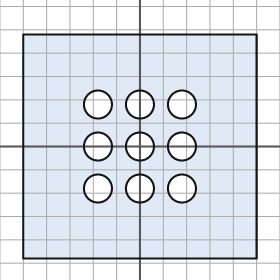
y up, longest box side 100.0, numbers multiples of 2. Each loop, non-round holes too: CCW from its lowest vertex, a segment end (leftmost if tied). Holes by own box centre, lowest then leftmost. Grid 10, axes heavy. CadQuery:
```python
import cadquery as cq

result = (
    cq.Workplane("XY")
    .moveTo(-50.0, -48.0)
    .lineTo(50.0, -48.0)
    .lineTo(50.0, 48.0)
    .lineTo(-50.0, 48.0)
    .close()
    .moveTo(-18.0, -18.0)
    .circle(6.0)
    .moveTo(0.0, -18.0)
    .circle(6.0)
    .moveTo(18.0, -18.0)
    .circle(6.0)
    .moveTo(-18.0, 0.0)
    .circle(6.0)
    .moveTo(0.0, 0.0)
    .circle(6.0)
    .moveTo(18.0, 0.0)
    .circle(6.0)
    .moveTo(-18.0, 18.0)
    .circle(6.0)
    .moveTo(0.0, 18.0)
    .circle(6.0)
    .moveTo(18.0, 18.0)
    .circle(6.0)
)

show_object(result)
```